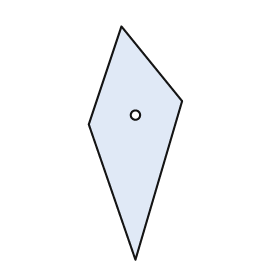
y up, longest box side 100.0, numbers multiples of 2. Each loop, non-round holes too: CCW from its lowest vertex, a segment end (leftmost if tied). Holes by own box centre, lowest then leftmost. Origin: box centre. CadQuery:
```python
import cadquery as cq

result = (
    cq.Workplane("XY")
    .moveTo(0.0, -50.0)
    .lineTo(20.0, 18.0)
    .lineTo(-6.0, 50.0)
    .lineTo(-20.0, 8.0)
    .close()
    .moveTo(0.0, 12.0)
    .circle(2.0)
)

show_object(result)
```